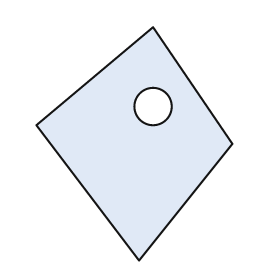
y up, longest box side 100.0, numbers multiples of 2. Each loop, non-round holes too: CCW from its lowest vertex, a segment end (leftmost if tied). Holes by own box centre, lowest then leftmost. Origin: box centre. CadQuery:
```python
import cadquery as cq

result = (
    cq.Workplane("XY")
    .moveTo(2.0, -50.0)
    .lineTo(42.0, 0.0)
    .lineTo(8.0, 50.0)
    .lineTo(-42.0, 8.0)
    .close()
    .moveTo(8.0, 16.0)
    .circle(8.0)
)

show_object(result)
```